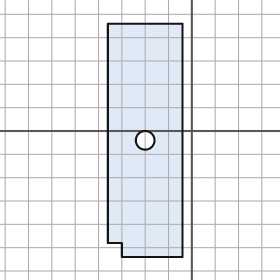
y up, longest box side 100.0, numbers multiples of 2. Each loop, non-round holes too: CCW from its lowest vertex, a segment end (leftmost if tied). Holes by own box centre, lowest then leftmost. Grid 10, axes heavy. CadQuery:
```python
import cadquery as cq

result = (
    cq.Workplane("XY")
    .moveTo(-30.0, -54.0)
    .lineTo(-4.0, -54.0)
    .lineTo(-4.0, 46.0)
    .lineTo(-36.0, 46.0)
    .lineTo(-36.0, -48.0)
    .lineTo(-30.0, -48.0)
    .close()
    .moveTo(-20.0, -4.0)
    .circle(4.0)
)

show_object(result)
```